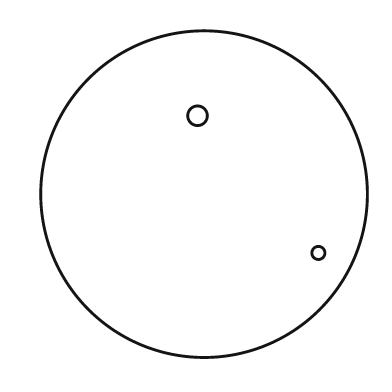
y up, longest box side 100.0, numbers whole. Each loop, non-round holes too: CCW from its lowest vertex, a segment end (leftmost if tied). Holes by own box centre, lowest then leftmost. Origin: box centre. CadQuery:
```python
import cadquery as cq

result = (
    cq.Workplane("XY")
    .moveTo(0.0, 0.0)
    .circle(50.0)
    .moveTo(35.0, -18.0)
    .circle(2.0)
    .moveTo(-2.0, 24.0)
    .circle(3.0)
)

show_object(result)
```